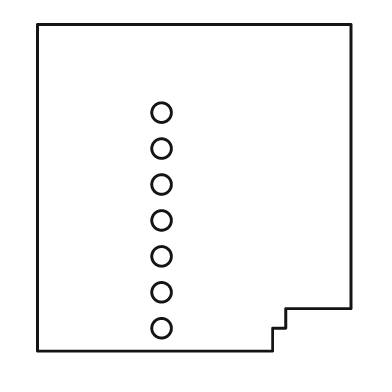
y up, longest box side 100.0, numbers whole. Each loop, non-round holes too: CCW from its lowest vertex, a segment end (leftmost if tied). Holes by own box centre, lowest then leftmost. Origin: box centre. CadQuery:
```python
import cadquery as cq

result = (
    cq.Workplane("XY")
    .moveTo(-48.0, -50.0)
    .lineTo(24.0, -50.0)
    .lineTo(24.0, -43.0)
    .lineTo(28.0, -43.0)
    .lineTo(28.0, -37.0)
    .lineTo(48.0, -37.0)
    .lineTo(48.0, 50.0)
    .lineTo(-48.0, 50.0)
    .close()
    .moveTo(-10.0, -43.0)
    .circle(3.0)
    .moveTo(-10.0, -32.0)
    .circle(3.0)
    .moveTo(-10.0, -21.0)
    .circle(3.0)
    .moveTo(-10.0, -10.0)
    .circle(3.0)
    .moveTo(-10.0, 1.0)
    .circle(3.0)
    .moveTo(-10.0, 12.0)
    .circle(3.0)
    .moveTo(-10.0, 23.0)
    .circle(3.0)
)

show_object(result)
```